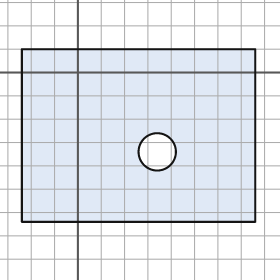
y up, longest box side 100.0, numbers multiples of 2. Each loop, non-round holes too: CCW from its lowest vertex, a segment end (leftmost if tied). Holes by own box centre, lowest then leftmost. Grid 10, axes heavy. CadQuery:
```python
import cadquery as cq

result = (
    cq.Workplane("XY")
    .moveTo(-24.0, -64.0)
    .lineTo(76.0, -64.0)
    .lineTo(76.0, 10.0)
    .lineTo(-24.0, 10.0)
    .close()
    .moveTo(34.0, -34.0)
    .circle(8.0)
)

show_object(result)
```